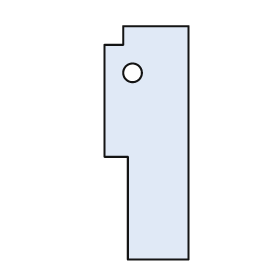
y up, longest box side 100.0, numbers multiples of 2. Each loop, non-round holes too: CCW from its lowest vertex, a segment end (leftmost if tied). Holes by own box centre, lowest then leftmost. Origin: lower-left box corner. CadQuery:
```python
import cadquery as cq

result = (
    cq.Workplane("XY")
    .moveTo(10.0, 0.0)
    .lineTo(36.0, 0.0)
    .lineTo(36.0, 100.0)
    .lineTo(8.0, 100.0)
    .lineTo(8.0, 92.0)
    .lineTo(0.0, 92.0)
    .lineTo(0.0, 44.0)
    .lineTo(10.0, 44.0)
    .close()
    .moveTo(12.0, 80.0)
    .circle(4.0)
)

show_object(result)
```